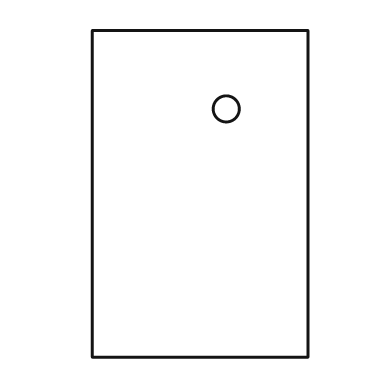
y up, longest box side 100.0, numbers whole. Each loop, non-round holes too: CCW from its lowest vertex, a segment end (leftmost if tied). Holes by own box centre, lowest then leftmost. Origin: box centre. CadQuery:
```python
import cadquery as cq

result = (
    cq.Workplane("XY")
    .moveTo(-33.0, -50.0)
    .lineTo(33.0, -50.0)
    .lineTo(33.0, 50.0)
    .lineTo(-33.0, 50.0)
    .close()
    .moveTo(8.0, 26.0)
    .circle(4.0)
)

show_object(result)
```